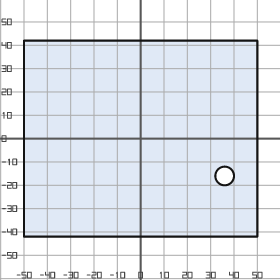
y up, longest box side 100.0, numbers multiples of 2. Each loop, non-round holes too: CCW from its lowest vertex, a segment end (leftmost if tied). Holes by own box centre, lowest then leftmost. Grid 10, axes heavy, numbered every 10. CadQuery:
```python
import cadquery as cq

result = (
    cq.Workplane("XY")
    .moveTo(-50.0, -42.0)
    .lineTo(50.0, -42.0)
    .lineTo(50.0, 42.0)
    .lineTo(-50.0, 42.0)
    .close()
    .moveTo(36.0, -16.0)
    .circle(4.0)
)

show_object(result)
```